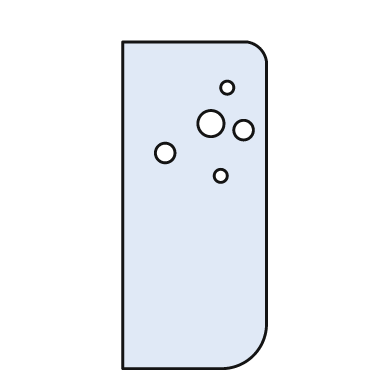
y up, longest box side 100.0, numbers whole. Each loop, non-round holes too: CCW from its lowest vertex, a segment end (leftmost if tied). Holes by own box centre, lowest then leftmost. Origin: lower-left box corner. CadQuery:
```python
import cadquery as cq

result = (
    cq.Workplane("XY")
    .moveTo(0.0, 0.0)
    .lineTo(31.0, 0.0)
    .threePointArc((40.0, 4.0), (44.0, 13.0))
    .lineTo(44.0, 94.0)
    .threePointArc((42.0, 98.0), (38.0, 100.0))
    .lineTo(0.0, 100.0)
    .close()
    .moveTo(30.0, 59.0)
    .circle(2.0)
    .moveTo(13.0, 66.0)
    .circle(3.0)
    .moveTo(37.0, 73.0)
    .circle(3.0)
    .moveTo(27.0, 75.0)
    .circle(4.0)
    .moveTo(32.0, 86.0)
    .circle(2.0)
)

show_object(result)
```